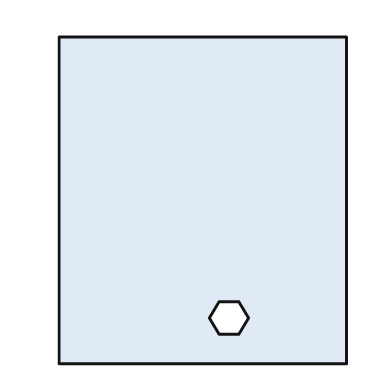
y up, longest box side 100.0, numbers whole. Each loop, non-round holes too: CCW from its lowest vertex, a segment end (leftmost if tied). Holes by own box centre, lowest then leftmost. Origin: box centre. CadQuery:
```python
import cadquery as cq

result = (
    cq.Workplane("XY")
    .moveTo(-44.0, -50.0)
    .lineTo(44.0, -50.0)
    .lineTo(44.0, 50.0)
    .lineTo(-44.0, 50.0)
    .close()
    .moveTo(5.0, -41.0)
    .lineTo(11.0, -41.0)
    .lineTo(14.0, -36.0)
    .lineTo(11.0, -31.0)
    .lineTo(5.0, -31.0)
    .lineTo(2.0, -36.0)
    .close()
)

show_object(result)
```